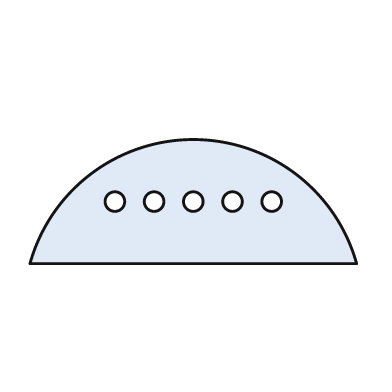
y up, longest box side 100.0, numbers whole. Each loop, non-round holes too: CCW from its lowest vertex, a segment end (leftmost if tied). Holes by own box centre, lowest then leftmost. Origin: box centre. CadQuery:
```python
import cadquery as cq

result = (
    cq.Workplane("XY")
    .moveTo(-50.0, -19.0)
    .lineTo(50.0, -19.0)
    .threePointArc((0.0, 19.0), (-50.0, -19.0))
    .close()
    .moveTo(-24.0, 0.0)
    .circle(3.0)
    .moveTo(-12.0, 0.0)
    .circle(3.0)
    .moveTo(0.0, 0.0)
    .circle(3.0)
    .moveTo(12.0, 0.0)
    .circle(3.0)
    .moveTo(24.0, 0.0)
    .circle(3.0)
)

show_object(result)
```